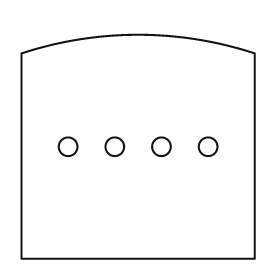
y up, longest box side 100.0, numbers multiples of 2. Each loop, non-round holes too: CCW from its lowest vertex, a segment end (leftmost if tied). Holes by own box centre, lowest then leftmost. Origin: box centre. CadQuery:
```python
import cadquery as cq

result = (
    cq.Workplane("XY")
    .moveTo(-50.0, -48.0)
    .lineTo(50.0, -48.0)
    .lineTo(50.0, 40.0)
    .threePointArc((0.0, 48.0), (-50.0, 40.0))
    .close()
    .moveTo(-30.0, 0.0)
    .circle(4.0)
    .moveTo(-10.0, 0.0)
    .circle(4.0)
    .moveTo(10.0, 0.0)
    .circle(4.0)
    .moveTo(30.0, 0.0)
    .circle(4.0)
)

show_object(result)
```